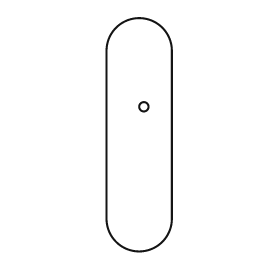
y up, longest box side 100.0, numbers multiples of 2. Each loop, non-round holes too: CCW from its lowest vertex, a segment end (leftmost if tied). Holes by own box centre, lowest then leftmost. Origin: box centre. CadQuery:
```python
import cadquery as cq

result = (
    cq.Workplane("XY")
    .moveTo(-14.0, -36.0)
    .threePointArc((0.0, -50.0), (14.0, -36.0))
    .lineTo(14.0, 36.0)
    .threePointArc((0.0, 50.0), (-14.0, 36.0))
    .close()
    .moveTo(2.0, 12.0)
    .circle(2.0)
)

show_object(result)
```